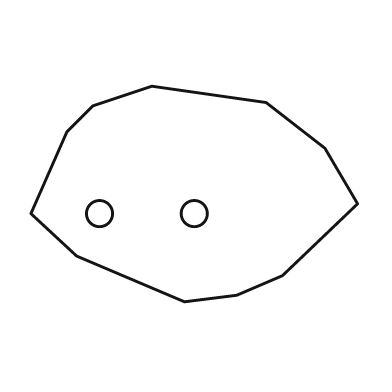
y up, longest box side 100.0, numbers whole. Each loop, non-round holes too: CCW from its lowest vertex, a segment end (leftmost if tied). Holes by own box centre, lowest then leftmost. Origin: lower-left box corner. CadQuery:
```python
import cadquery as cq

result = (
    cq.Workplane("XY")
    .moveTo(47.0, 0.0)
    .lineTo(63.0, 2.0)
    .lineTo(77.0, 8.0)
    .lineTo(100.0, 30.0)
    .lineTo(90.0, 47.0)
    .lineTo(72.0, 61.0)
    .lineTo(37.0, 66.0)
    .lineTo(19.0, 60.0)
    .lineTo(11.0, 52.0)
    .lineTo(0.0, 27.0)
    .lineTo(14.0, 14.0)
    .close()
    .moveTo(21.0, 27.0)
    .circle(4.0)
    .moveTo(50.0, 27.0)
    .circle(4.0)
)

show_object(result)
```